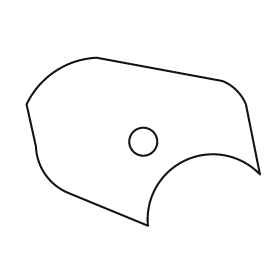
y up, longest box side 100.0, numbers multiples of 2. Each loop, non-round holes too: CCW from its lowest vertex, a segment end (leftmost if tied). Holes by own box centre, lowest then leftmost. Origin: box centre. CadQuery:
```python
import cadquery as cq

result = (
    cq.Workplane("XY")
    .moveTo(2.0, -36.0)
    .threePointArc((18.0, -8.0), (50.0, -14.0))
    .lineTo(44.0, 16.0)
    .threePointArc((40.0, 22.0), (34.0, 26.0))
    .lineTo(-20.0, 36.0)
    .threePointArc((-38.0, 30.0), (-50.0, 16.0))
    .lineTo(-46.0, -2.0)
    .threePointArc((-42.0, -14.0), (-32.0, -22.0))
    .close()
    .moveTo(0.0, 0.0)
    .circle(6.0)
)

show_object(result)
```